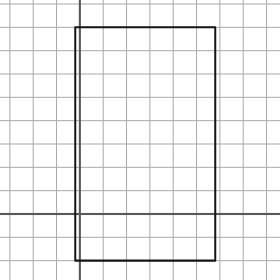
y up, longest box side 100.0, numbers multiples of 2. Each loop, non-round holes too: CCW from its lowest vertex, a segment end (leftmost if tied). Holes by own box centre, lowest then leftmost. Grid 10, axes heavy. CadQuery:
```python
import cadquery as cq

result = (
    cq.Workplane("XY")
    .moveTo(-2.0, -20.0)
    .lineTo(58.0, -20.0)
    .lineTo(58.0, 80.0)
    .lineTo(-2.0, 80.0)
    .close()
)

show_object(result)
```